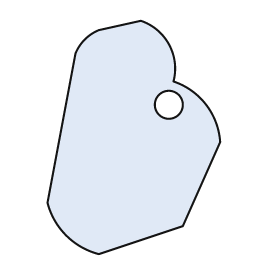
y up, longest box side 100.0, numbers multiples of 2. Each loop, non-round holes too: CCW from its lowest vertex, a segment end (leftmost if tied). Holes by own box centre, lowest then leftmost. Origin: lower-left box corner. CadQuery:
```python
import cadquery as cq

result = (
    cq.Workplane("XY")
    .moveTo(22.0, 0.0)
    .lineTo(58.0, 12.0)
    .lineTo(74.0, 48.0)
    .threePointArc((68.0, 64.0), (54.0, 74.0))
    .threePointArc((52.0, 90.0), (40.0, 100.0))
    .lineTo(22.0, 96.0)
    .threePointArc((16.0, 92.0), (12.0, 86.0))
    .lineTo(0.0, 22.0)
    .threePointArc((8.0, 8.0), (22.0, 0.0))
    .close()
    .moveTo(52.0, 64.0)
    .circle(6.0)
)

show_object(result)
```